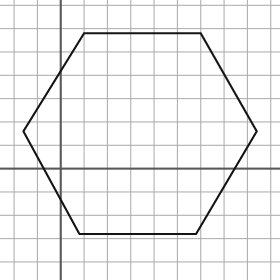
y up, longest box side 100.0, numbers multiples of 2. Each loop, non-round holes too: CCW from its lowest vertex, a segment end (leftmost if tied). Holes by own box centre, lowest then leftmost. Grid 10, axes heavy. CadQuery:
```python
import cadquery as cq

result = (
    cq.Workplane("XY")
    .moveTo(8.0, -28.0)
    .lineTo(58.0, -28.0)
    .lineTo(84.0, 16.0)
    .lineTo(60.0, 58.0)
    .lineTo(10.0, 58.0)
    .lineTo(-16.0, 16.0)
    .close()
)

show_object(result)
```